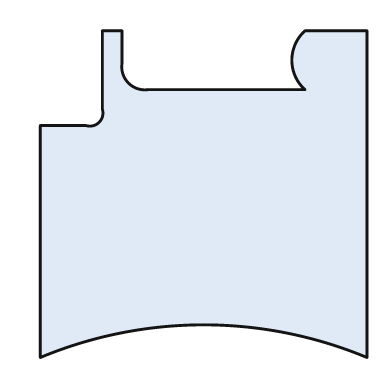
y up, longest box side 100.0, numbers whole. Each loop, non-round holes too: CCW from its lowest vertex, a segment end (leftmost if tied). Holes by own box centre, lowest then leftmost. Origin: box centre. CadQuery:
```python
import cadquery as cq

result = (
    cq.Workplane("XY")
    .moveTo(-50.0, -50.0)
    .threePointArc((0.0, -40.0), (50.0, -50.0))
    .lineTo(50.0, 50.0)
    .lineTo(31.0, 50.0)
    .threePointArc((27.0, 41.0), (31.0, 32.0))
    .lineTo(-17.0, 32.0)
    .threePointArc((-23.0, 34.0), (-25.0, 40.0))
    .lineTo(-25.0, 50.0)
    .lineTo(-31.0, 50.0)
    .lineTo(-31.0, 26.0)
    .threePointArc((-32.0, 22.0), (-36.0, 21.0))
    .lineTo(-50.0, 21.0)
    .close()
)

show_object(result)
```